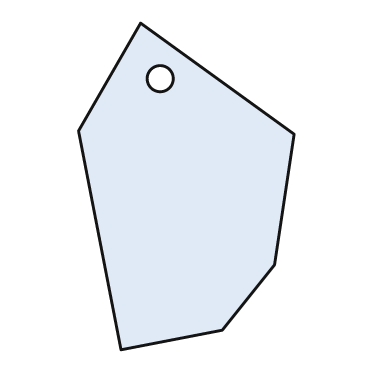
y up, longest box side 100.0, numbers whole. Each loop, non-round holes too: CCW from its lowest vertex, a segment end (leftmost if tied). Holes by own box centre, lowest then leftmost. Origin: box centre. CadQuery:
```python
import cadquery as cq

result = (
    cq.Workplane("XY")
    .moveTo(-20.0, -50.0)
    .lineTo(11.0, -44.0)
    .lineTo(27.0, -24.0)
    .lineTo(33.0, 16.0)
    .lineTo(-14.0, 50.0)
    .lineTo(-33.0, 17.0)
    .close()
    .moveTo(-8.0, 33.0)
    .circle(4.0)
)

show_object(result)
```